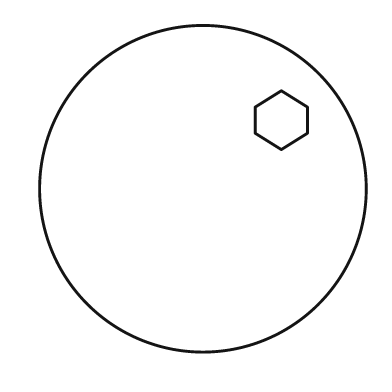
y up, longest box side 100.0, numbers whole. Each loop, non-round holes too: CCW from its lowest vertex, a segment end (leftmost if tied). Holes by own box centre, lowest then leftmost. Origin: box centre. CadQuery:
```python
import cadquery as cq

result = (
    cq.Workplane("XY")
    .moveTo(0.0, 0.0)
    .circle(50.0)
    .moveTo(24.0, 12.0)
    .lineTo(32.0, 17.0)
    .lineTo(32.0, 25.0)
    .lineTo(24.0, 30.0)
    .lineTo(16.0, 25.0)
    .lineTo(16.0, 17.0)
    .close()
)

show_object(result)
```